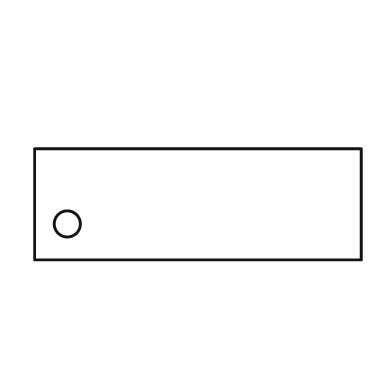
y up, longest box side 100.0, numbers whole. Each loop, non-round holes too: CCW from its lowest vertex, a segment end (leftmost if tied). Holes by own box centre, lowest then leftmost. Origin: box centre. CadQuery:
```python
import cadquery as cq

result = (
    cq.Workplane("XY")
    .moveTo(-50.0, -17.0)
    .lineTo(50.0, -17.0)
    .lineTo(50.0, 17.0)
    .lineTo(-50.0, 17.0)
    .close()
    .moveTo(-40.0, -6.0)
    .circle(4.0)
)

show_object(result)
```